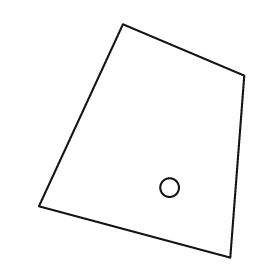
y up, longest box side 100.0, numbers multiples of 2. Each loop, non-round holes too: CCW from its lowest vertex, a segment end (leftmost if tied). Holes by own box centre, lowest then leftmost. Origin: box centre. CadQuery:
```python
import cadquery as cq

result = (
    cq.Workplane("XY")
    .moveTo(38.0, -50.0)
    .lineTo(44.0, 28.0)
    .lineTo(-8.0, 50.0)
    .lineTo(-44.0, -28.0)
    .close()
    .moveTo(12.0, -20.0)
    .circle(4.0)
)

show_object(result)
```